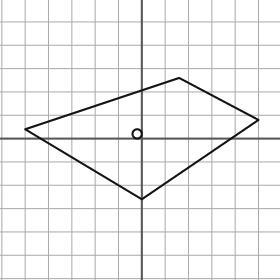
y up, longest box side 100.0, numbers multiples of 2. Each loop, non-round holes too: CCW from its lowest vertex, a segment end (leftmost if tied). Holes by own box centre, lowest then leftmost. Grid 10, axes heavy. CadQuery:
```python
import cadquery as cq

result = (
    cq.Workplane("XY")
    .moveTo(0.0, -26.0)
    .lineTo(50.0, 8.0)
    .lineTo(16.0, 26.0)
    .lineTo(-50.0, 4.0)
    .close()
    .moveTo(-2.0, 2.0)
    .circle(2.0)
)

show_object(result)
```